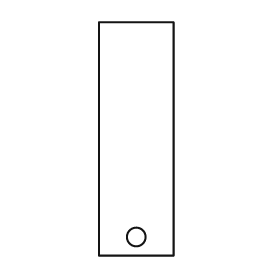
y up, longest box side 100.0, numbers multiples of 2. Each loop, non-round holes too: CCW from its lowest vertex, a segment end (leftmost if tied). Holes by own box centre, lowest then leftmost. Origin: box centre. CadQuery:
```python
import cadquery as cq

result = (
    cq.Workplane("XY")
    .moveTo(-16.0, -50.0)
    .lineTo(16.0, -50.0)
    .lineTo(16.0, 50.0)
    .lineTo(-16.0, 50.0)
    .close()
    .moveTo(0.0, -42.0)
    .circle(4.0)
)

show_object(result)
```